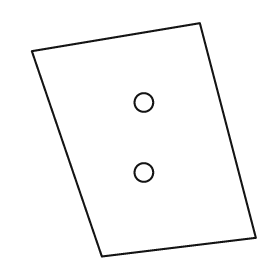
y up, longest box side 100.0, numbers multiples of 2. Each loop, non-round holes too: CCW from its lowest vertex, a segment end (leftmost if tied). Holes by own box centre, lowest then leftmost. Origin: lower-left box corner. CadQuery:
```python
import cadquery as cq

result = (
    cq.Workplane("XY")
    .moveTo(30.0, 0.0)
    .lineTo(96.0, 8.0)
    .lineTo(72.0, 100.0)
    .lineTo(0.0, 88.0)
    .close()
    .moveTo(48.0, 36.0)
    .circle(4.0)
    .moveTo(48.0, 66.0)
    .circle(4.0)
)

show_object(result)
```